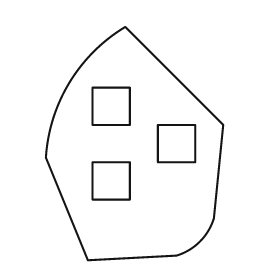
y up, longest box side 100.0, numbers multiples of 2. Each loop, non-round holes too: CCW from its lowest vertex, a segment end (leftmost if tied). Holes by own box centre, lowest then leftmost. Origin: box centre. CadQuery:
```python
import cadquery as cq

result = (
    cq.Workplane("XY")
    .moveTo(-20.0, -50.0)
    .lineTo(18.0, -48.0)
    .threePointArc((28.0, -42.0), (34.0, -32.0))
    .lineTo(38.0, 8.0)
    .lineTo(-4.0, 50.0)
    .threePointArc((-28.0, 26.0), (-38.0, -6.0))
    .close()
    .moveTo(-18.0, -24.0)
    .lineTo(-2.0, -24.0)
    .lineTo(-2.0, -8.0)
    .lineTo(-18.0, -8.0)
    .close()
    .moveTo(10.0, -8.0)
    .lineTo(26.0, -8.0)
    .lineTo(26.0, 8.0)
    .lineTo(10.0, 8.0)
    .close()
    .moveTo(-18.0, 8.0)
    .lineTo(-2.0, 8.0)
    .lineTo(-2.0, 24.0)
    .lineTo(-18.0, 24.0)
    .close()
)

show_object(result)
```